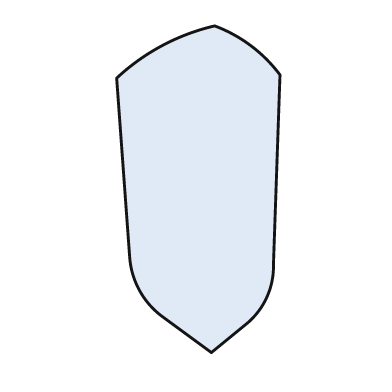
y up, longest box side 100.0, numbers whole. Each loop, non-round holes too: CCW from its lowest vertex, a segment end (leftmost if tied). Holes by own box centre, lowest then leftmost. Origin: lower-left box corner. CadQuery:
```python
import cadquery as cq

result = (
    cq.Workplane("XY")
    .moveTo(29.0, 0.0)
    .lineTo(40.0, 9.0)
    .threePointArc((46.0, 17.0), (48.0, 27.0))
    .lineTo(50.0, 85.0)
    .threePointArc((41.0, 94.0), (30.0, 100.0))
    .threePointArc((14.0, 94.0), (0.0, 84.0))
    .lineTo(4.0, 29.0)
    .threePointArc((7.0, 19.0), (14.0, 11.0))
    .close()
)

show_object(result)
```